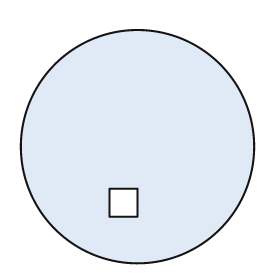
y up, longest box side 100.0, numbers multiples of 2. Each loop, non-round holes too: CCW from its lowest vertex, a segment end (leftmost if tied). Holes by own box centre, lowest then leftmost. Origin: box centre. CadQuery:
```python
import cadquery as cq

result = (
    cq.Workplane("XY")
    .moveTo(0.0, 0.0)
    .circle(50.0)
    .moveTo(-12.0, -30.0)
    .lineTo(0.0, -30.0)
    .lineTo(0.0, -18.0)
    .lineTo(-12.0, -18.0)
    .close()
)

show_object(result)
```